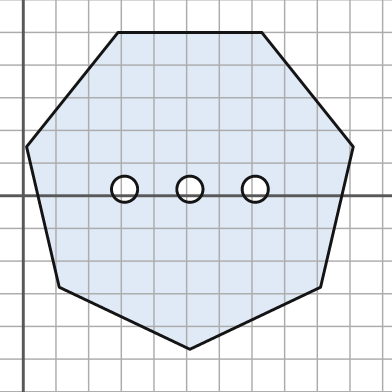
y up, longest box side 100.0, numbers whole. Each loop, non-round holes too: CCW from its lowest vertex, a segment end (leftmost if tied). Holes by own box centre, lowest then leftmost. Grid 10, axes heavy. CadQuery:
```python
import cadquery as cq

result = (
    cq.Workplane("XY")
    .moveTo(51.0, -47.0)
    .lineTo(91.0, -28.0)
    .lineTo(101.0, 15.0)
    .lineTo(73.0, 50.0)
    .lineTo(29.0, 50.0)
    .lineTo(1.0, 15.0)
    .lineTo(11.0, -28.0)
    .close()
    .moveTo(31.0, 2.0)
    .circle(4.0)
    .moveTo(51.0, 2.0)
    .circle(4.0)
    .moveTo(71.0, 2.0)
    .circle(4.0)
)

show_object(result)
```